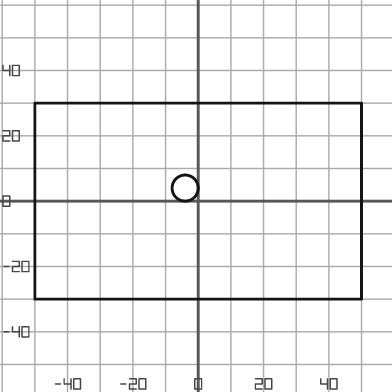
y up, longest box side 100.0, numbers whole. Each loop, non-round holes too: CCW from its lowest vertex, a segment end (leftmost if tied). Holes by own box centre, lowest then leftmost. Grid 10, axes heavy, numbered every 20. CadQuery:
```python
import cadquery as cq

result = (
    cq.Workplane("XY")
    .moveTo(-50.0, -30.0)
    .lineTo(50.0, -30.0)
    .lineTo(50.0, 30.0)
    .lineTo(-50.0, 30.0)
    .close()
    .moveTo(-4.0, 4.0)
    .circle(4.0)
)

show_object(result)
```